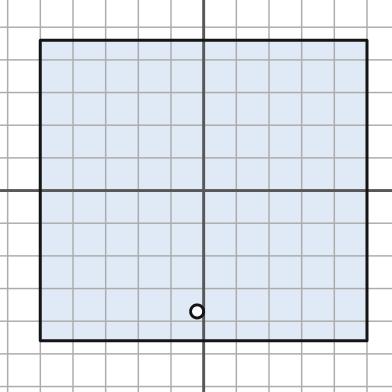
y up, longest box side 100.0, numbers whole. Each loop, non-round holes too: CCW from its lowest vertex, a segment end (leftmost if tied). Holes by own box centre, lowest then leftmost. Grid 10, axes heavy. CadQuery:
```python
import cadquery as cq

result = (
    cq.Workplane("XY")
    .moveTo(-50.0, -46.0)
    .lineTo(50.0, -46.0)
    .lineTo(50.0, 46.0)
    .lineTo(-50.0, 46.0)
    .close()
    .moveTo(-2.0, -37.0)
    .circle(2.0)
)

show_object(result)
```